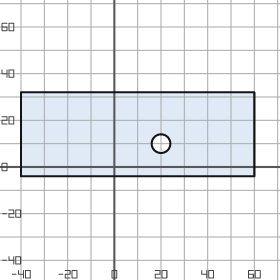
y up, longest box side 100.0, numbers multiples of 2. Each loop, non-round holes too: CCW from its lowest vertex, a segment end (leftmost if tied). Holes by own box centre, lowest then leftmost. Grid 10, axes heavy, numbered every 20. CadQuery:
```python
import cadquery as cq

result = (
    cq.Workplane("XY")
    .moveTo(-40.0, -4.0)
    .lineTo(60.0, -4.0)
    .lineTo(60.0, 32.0)
    .lineTo(-40.0, 32.0)
    .close()
    .moveTo(20.0, 10.0)
    .circle(4.0)
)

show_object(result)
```